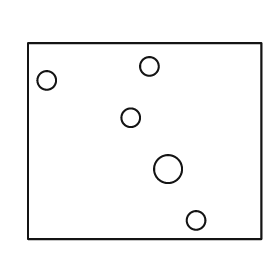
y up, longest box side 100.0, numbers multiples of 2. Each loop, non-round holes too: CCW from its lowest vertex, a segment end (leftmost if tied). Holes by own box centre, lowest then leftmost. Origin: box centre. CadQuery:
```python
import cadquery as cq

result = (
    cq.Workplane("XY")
    .moveTo(-50.0, -42.0)
    .lineTo(50.0, -42.0)
    .lineTo(50.0, 42.0)
    .lineTo(-50.0, 42.0)
    .close()
    .moveTo(22.0, -34.0)
    .circle(4.0)
    .moveTo(10.0, -12.0)
    .circle(6.0)
    .moveTo(-6.0, 10.0)
    .circle(4.0)
    .moveTo(-42.0, 26.0)
    .circle(4.0)
    .moveTo(2.0, 32.0)
    .circle(4.0)
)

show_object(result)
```